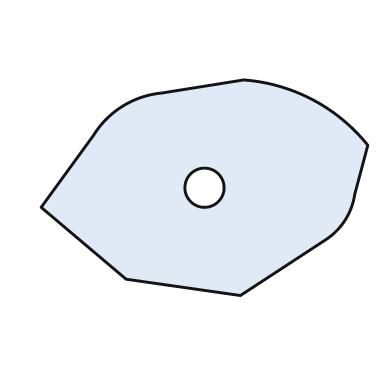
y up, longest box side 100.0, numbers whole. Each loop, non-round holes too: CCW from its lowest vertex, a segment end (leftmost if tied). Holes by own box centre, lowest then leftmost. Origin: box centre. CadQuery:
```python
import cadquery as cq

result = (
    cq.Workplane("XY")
    .moveTo(11.0, -33.0)
    .lineTo(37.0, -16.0)
    .threePointArc((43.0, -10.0), (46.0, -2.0))
    .lineTo(50.0, 13.0)
    .threePointArc((33.0, 27.0), (12.0, 33.0))
    .lineTo(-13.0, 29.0)
    .threePointArc((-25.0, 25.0), (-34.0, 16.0))
    .lineTo(-50.0, -6.0)
    .lineTo(-24.0, -28.0)
    .close()
    .moveTo(0.0, 0.0)
    .circle(6.0)
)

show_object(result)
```